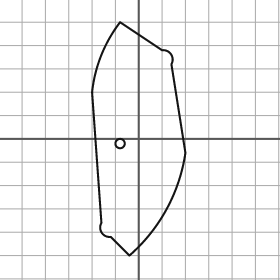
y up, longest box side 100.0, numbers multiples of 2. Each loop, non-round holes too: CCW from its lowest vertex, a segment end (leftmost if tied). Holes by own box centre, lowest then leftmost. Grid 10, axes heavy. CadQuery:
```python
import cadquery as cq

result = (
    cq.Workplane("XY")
    .moveTo(-4.0, -50.0)
    .threePointArc((12.0, -30.0), (20.0, -6.0))
    .lineTo(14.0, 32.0)
    .threePointArc((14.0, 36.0), (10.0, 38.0))
    .lineTo(-8.0, 50.0)
    .threePointArc((-16.0, 36.0), (-20.0, 20.0))
    .lineTo(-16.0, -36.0)
    .threePointArc((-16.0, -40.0), (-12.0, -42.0))
    .close()
    .moveTo(-8.0, -2.0)
    .circle(2.0)
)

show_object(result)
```